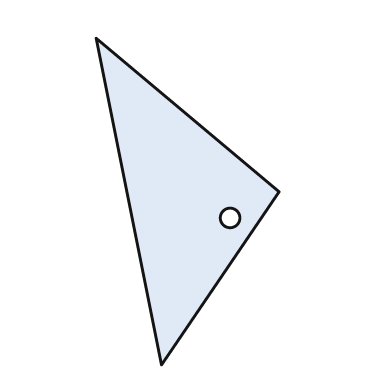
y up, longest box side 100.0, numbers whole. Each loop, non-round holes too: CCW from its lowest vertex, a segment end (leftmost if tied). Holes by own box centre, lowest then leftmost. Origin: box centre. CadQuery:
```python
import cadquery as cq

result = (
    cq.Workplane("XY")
    .moveTo(-8.0, -50.0)
    .lineTo(28.0, 3.0)
    .lineTo(-28.0, 50.0)
    .close()
    .moveTo(13.0, -5.0)
    .circle(3.0)
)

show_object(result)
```